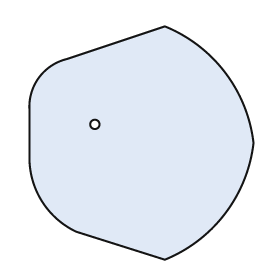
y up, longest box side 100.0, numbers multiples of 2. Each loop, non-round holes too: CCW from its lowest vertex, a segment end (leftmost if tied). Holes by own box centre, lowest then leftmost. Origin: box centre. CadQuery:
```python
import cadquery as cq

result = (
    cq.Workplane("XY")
    .moveTo(10.0, -50.0)
    .threePointArc((36.0, -30.0), (48.0, 0.0))
    .threePointArc((36.0, 30.0), (10.0, 50.0))
    .lineTo(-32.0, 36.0)
    .threePointArc((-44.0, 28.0), (-48.0, 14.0))
    .lineTo(-48.0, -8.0)
    .threePointArc((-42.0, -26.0), (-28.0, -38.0))
    .close()
    .moveTo(-20.0, 8.0)
    .circle(2.0)
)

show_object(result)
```